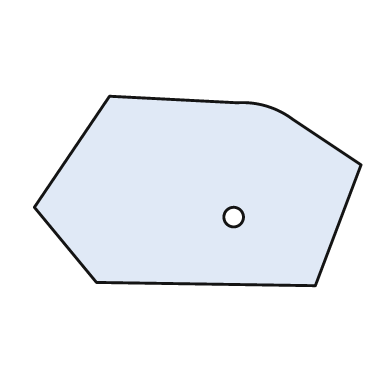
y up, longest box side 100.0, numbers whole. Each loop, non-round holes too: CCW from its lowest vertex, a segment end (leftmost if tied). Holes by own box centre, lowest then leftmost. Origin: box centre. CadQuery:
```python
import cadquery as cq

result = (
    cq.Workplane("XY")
    .moveTo(36.0, -29.0)
    .lineTo(50.0, 8.0)
    .lineTo(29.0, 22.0)
    .threePointArc((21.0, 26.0), (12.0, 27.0))
    .lineTo(-27.0, 29.0)
    .lineTo(-50.0, -5.0)
    .lineTo(-31.0, -28.0)
    .close()
    .moveTo(11.0, -8.0)
    .circle(3.0)
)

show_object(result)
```